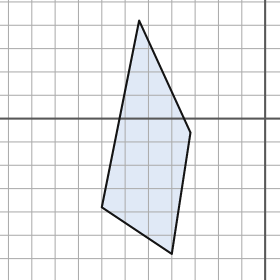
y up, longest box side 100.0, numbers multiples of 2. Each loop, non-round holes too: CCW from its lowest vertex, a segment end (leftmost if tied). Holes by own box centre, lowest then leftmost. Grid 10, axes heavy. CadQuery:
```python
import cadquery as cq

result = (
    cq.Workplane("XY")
    .moveTo(-40.0, -58.0)
    .lineTo(-32.0, -6.0)
    .lineTo(-54.0, 42.0)
    .lineTo(-70.0, -38.0)
    .close()
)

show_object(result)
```